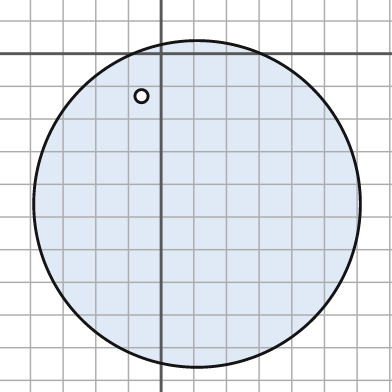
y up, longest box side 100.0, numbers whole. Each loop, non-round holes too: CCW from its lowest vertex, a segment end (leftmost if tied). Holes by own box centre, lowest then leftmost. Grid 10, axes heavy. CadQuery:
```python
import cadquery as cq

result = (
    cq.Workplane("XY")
    .moveTo(11.0, -46.0)
    .circle(50.0)
    .moveTo(-6.0, -13.0)
    .circle(2.0)
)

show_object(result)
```